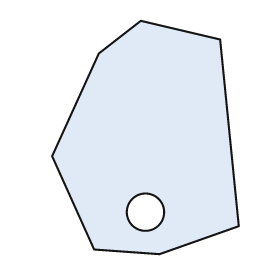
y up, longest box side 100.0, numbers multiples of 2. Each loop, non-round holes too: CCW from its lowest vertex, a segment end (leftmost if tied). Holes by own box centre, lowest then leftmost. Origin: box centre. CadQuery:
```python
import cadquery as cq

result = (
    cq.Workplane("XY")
    .moveTo(6.0, -50.0)
    .lineTo(40.0, -38.0)
    .lineTo(32.0, 42.0)
    .lineTo(-2.0, 50.0)
    .lineTo(-20.0, 36.0)
    .lineTo(-40.0, -8.0)
    .lineTo(-22.0, -48.0)
    .close()
    .moveTo(0.0, -32.0)
    .circle(8.0)
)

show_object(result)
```